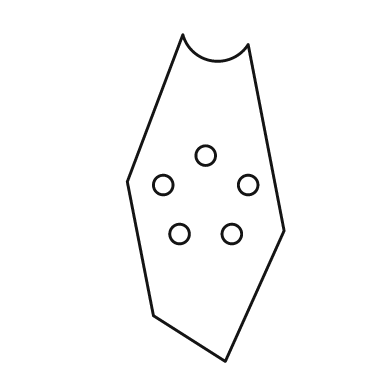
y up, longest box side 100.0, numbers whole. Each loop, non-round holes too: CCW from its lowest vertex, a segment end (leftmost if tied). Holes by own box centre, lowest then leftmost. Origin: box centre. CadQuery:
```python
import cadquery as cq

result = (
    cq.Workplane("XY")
    .moveTo(6.0, -50.0)
    .lineTo(24.0, -10.0)
    .lineTo(13.0, 47.0)
    .threePointArc((2.0, 42.0), (-7.0, 50.0))
    .lineTo(-24.0, 5.0)
    .lineTo(-16.0, -36.0)
    .close()
    .moveTo(-8.0, -11.0)
    .circle(3.0)
    .moveTo(8.0, -11.0)
    .circle(3.0)
    .moveTo(-13.0, 4.0)
    .circle(3.0)
    .moveTo(13.0, 4.0)
    .circle(3.0)
    .moveTo(0.0, 13.0)
    .circle(3.0)
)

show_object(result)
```